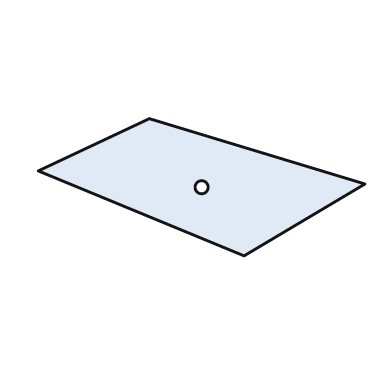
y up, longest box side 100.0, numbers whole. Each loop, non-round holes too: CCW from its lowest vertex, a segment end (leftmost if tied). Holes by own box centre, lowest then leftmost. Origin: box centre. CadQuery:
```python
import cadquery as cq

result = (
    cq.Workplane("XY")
    .moveTo(13.0, -21.0)
    .lineTo(50.0, 1.0)
    .lineTo(-16.0, 21.0)
    .lineTo(-50.0, 5.0)
    .close()
    .moveTo(0.0, 0.0)
    .circle(2.0)
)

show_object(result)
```